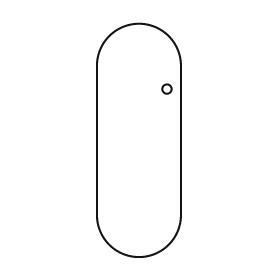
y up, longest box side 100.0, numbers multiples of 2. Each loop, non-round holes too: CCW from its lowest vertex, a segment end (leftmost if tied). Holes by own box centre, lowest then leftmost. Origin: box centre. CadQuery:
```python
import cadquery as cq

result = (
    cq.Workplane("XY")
    .moveTo(-18.0, -32.0)
    .threePointArc((0.0, -50.0), (18.0, -32.0))
    .lineTo(18.0, 32.0)
    .threePointArc((0.0, 50.0), (-18.0, 32.0))
    .close()
    .moveTo(12.0, 22.0)
    .circle(2.0)
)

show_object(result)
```